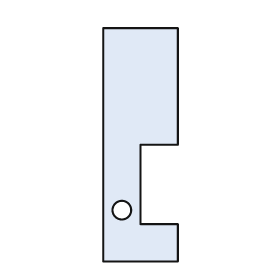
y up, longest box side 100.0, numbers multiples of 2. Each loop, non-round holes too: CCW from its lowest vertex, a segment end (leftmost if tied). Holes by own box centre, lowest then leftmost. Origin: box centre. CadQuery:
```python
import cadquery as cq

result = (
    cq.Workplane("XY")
    .moveTo(-16.0, -50.0)
    .lineTo(16.0, -50.0)
    .lineTo(16.0, -34.0)
    .lineTo(0.0, -34.0)
    .lineTo(0.0, 0.0)
    .lineTo(16.0, 0.0)
    .lineTo(16.0, 50.0)
    .lineTo(-16.0, 50.0)
    .close()
    .moveTo(-8.0, -28.0)
    .circle(4.0)
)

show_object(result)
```